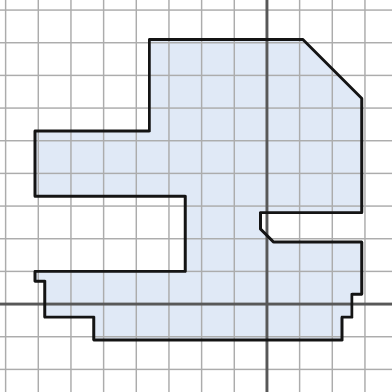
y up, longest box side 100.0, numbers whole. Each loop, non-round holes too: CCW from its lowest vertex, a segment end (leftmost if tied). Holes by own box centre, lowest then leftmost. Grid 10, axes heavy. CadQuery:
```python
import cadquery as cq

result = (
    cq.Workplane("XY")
    .moveTo(-53.0, -11.0)
    .lineTo(23.0, -11.0)
    .lineTo(23.0, -4.0)
    .lineTo(26.0, -4.0)
    .lineTo(26.0, 3.0)
    .lineTo(29.0, 3.0)
    .lineTo(29.0, 19.0)
    .lineTo(2.0, 19.0)
    .lineTo(-2.0, 23.0)
    .lineTo(-2.0, 28.0)
    .lineTo(29.0, 28.0)
    .lineTo(29.0, 63.0)
    .lineTo(11.0, 81.0)
    .lineTo(-36.0, 81.0)
    .lineTo(-36.0, 53.0)
    .lineTo(-71.0, 53.0)
    .lineTo(-71.0, 33.0)
    .lineTo(-25.0, 33.0)
    .lineTo(-25.0, 10.0)
    .lineTo(-71.0, 10.0)
    .lineTo(-71.0, 7.0)
    .lineTo(-68.0, 7.0)
    .lineTo(-68.0, -4.0)
    .lineTo(-53.0, -4.0)
    .close()
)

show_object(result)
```